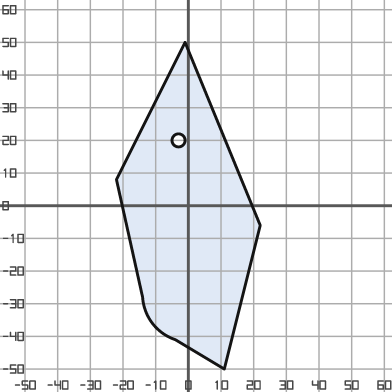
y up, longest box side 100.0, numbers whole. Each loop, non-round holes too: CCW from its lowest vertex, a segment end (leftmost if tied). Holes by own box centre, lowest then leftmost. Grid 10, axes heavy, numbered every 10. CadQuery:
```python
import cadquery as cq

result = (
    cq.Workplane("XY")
    .moveTo(11.0, -50.0)
    .lineTo(22.0, -6.0)
    .lineTo(-1.0, 50.0)
    .lineTo(-22.0, 8.0)
    .lineTo(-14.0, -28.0)
    .threePointArc((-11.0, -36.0), (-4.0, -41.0))
    .close()
    .moveTo(-3.0, 20.0)
    .circle(2.0)
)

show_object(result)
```